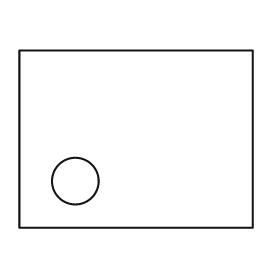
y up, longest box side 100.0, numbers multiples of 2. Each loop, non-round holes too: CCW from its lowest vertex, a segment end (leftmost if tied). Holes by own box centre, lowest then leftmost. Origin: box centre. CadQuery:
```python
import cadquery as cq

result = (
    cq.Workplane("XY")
    .moveTo(-50.0, -38.0)
    .lineTo(50.0, -38.0)
    .lineTo(50.0, 38.0)
    .lineTo(-50.0, 38.0)
    .close()
    .moveTo(-26.0, -18.0)
    .circle(10.0)
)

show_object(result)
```